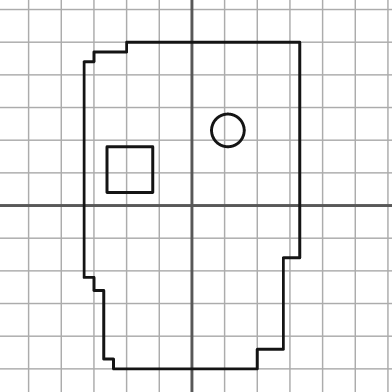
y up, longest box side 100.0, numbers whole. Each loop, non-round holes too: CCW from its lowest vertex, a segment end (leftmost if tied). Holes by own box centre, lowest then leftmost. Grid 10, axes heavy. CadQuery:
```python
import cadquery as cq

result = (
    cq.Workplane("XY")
    .moveTo(-24.0, -50.0)
    .lineTo(20.0, -50.0)
    .lineTo(20.0, -44.0)
    .lineTo(28.0, -44.0)
    .lineTo(28.0, -16.0)
    .lineTo(33.0, -16.0)
    .lineTo(33.0, 50.0)
    .lineTo(-20.0, 50.0)
    .lineTo(-20.0, 47.0)
    .lineTo(-30.0, 47.0)
    .lineTo(-30.0, 44.0)
    .lineTo(-33.0, 44.0)
    .lineTo(-33.0, -22.0)
    .lineTo(-30.0, -22.0)
    .lineTo(-30.0, -26.0)
    .lineTo(-27.0, -26.0)
    .lineTo(-27.0, -47.0)
    .lineTo(-24.0, -47.0)
    .close()
    .moveTo(-26.0, 4.0)
    .lineTo(-12.0, 4.0)
    .lineTo(-12.0, 18.0)
    .lineTo(-26.0, 18.0)
    .close()
    .moveTo(11.0, 23.0)
    .circle(5.0)
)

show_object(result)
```